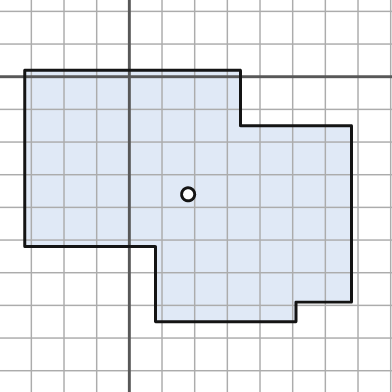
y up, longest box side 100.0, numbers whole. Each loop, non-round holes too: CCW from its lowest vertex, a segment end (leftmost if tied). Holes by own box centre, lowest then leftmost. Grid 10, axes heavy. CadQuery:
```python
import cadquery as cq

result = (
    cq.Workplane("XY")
    .moveTo(8.0, -75.0)
    .lineTo(51.0, -75.0)
    .lineTo(51.0, -69.0)
    .lineTo(68.0, -69.0)
    .lineTo(68.0, -15.0)
    .lineTo(34.0, -15.0)
    .lineTo(34.0, 2.0)
    .lineTo(-32.0, 2.0)
    .lineTo(-32.0, -52.0)
    .lineTo(8.0, -52.0)
    .close()
    .moveTo(18.0, -36.0)
    .circle(2.0)
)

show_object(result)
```